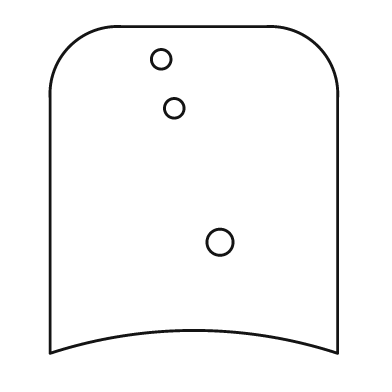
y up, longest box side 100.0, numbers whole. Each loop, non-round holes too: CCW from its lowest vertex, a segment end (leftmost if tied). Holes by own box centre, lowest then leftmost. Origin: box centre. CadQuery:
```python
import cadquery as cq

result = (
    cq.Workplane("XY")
    .moveTo(-44.0, -50.0)
    .threePointArc((0.0, -43.0), (44.0, -50.0))
    .lineTo(44.0, 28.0)
    .threePointArc((38.0, 44.0), (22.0, 50.0))
    .lineTo(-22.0, 50.0)
    .threePointArc((-38.0, 44.0), (-44.0, 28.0))
    .close()
    .moveTo(8.0, -16.0)
    .circle(4.0)
    .moveTo(-6.0, 25.0)
    .circle(3.0)
    .moveTo(-10.0, 40.0)
    .circle(3.0)
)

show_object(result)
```